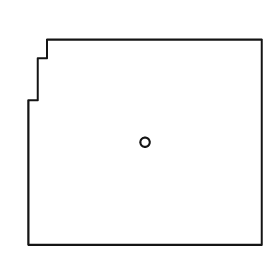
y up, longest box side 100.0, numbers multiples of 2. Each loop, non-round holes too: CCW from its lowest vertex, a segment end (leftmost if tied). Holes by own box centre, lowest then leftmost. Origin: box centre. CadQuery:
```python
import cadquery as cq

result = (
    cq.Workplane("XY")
    .moveTo(-50.0, -44.0)
    .lineTo(50.0, -44.0)
    .lineTo(50.0, 44.0)
    .lineTo(-42.0, 44.0)
    .lineTo(-42.0, 36.0)
    .lineTo(-46.0, 36.0)
    .lineTo(-46.0, 18.0)
    .lineTo(-50.0, 18.0)
    .close()
    .moveTo(0.0, 0.0)
    .circle(2.0)
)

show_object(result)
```